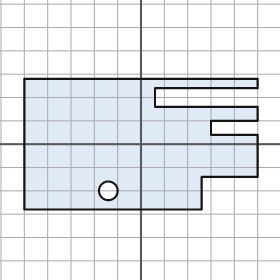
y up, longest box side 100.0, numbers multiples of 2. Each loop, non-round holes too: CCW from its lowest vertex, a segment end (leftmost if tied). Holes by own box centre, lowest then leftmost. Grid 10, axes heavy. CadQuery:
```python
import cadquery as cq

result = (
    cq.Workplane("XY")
    .moveTo(-50.0, -28.0)
    .lineTo(26.0, -28.0)
    .lineTo(26.0, -14.0)
    .lineTo(50.0, -14.0)
    .lineTo(50.0, 4.0)
    .lineTo(30.0, 4.0)
    .lineTo(30.0, 10.0)
    .lineTo(50.0, 10.0)
    .lineTo(50.0, 16.0)
    .lineTo(6.0, 16.0)
    .lineTo(6.0, 24.0)
    .lineTo(50.0, 24.0)
    .lineTo(50.0, 28.0)
    .lineTo(-50.0, 28.0)
    .close()
    .moveTo(-14.0, -20.0)
    .circle(4.0)
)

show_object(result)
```